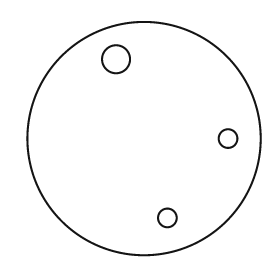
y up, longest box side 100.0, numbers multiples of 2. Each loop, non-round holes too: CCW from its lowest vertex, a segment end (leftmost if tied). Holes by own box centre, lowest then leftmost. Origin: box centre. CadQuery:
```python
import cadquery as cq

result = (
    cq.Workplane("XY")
    .moveTo(0.0, 0.0)
    .circle(50.0)
    .moveTo(10.0, -34.0)
    .circle(4.0)
    .moveTo(36.0, 0.0)
    .circle(4.0)
    .moveTo(-12.0, 34.0)
    .circle(6.0)
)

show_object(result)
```